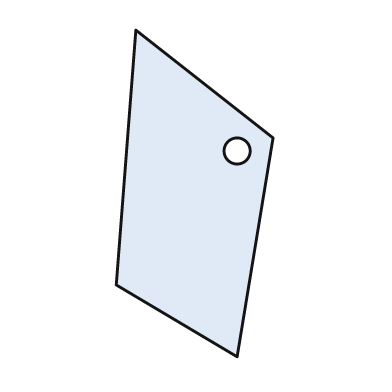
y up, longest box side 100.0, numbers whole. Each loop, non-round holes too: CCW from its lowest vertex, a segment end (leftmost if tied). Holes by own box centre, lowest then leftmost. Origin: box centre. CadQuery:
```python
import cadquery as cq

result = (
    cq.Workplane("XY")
    .moveTo(13.0, -50.0)
    .lineTo(24.0, 17.0)
    .lineTo(-18.0, 50.0)
    .lineTo(-24.0, -28.0)
    .close()
    .moveTo(13.0, 13.0)
    .circle(4.0)
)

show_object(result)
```